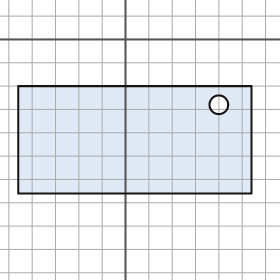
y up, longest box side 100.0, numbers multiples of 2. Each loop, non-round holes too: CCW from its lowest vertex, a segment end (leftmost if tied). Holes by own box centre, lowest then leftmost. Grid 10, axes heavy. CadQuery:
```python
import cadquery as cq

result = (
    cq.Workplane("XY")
    .moveTo(-46.0, -66.0)
    .lineTo(54.0, -66.0)
    .lineTo(54.0, -20.0)
    .lineTo(-46.0, -20.0)
    .close()
    .moveTo(40.0, -28.0)
    .circle(4.0)
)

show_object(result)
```